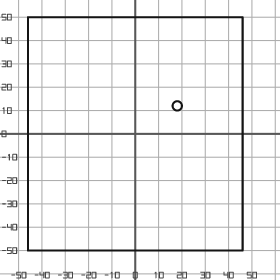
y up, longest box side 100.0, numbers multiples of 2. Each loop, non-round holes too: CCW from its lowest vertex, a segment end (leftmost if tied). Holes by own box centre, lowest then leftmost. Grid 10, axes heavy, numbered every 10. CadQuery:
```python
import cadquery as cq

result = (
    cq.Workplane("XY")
    .moveTo(-46.0, -50.0)
    .lineTo(46.0, -50.0)
    .lineTo(46.0, 50.0)
    .lineTo(-46.0, 50.0)
    .close()
    .moveTo(18.0, 12.0)
    .circle(2.0)
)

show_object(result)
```